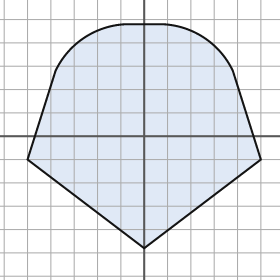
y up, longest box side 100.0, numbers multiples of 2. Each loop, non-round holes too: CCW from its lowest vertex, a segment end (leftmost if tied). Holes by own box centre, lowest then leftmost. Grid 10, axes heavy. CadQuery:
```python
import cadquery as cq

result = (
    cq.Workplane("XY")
    .moveTo(0.0, -48.0)
    .lineTo(50.0, -10.0)
    .lineTo(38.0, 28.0)
    .threePointArc((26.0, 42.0), (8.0, 48.0))
    .lineTo(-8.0, 48.0)
    .threePointArc((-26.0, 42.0), (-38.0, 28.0))
    .lineTo(-50.0, -10.0)
    .close()
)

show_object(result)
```